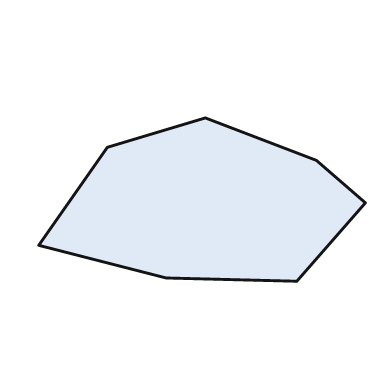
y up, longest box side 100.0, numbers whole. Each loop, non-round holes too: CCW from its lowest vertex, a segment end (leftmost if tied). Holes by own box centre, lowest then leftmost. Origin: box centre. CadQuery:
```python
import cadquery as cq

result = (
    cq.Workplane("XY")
    .moveTo(29.0, -25.0)
    .lineTo(50.0, -1.0)
    .lineTo(35.0, 12.0)
    .lineTo(1.0, 25.0)
    .lineTo(-29.0, 16.0)
    .lineTo(-50.0, -14.0)
    .lineTo(-11.0, -24.0)
    .close()
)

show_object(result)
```